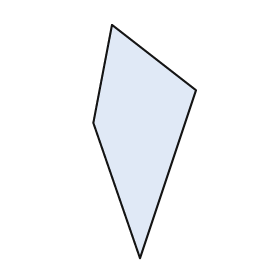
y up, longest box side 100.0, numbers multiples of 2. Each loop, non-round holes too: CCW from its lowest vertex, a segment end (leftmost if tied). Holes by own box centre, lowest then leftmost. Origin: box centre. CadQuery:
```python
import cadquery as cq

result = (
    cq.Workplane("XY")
    .moveTo(-2.0, -50.0)
    .lineTo(22.0, 22.0)
    .lineTo(-14.0, 50.0)
    .lineTo(-22.0, 8.0)
    .close()
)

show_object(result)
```